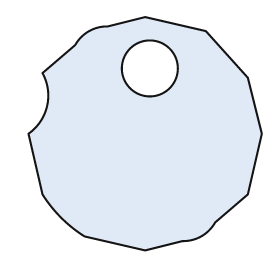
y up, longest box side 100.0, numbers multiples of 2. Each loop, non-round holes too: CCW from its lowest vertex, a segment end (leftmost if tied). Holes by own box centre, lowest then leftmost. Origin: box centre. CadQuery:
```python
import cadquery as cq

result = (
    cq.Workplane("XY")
    .moveTo(0.0, -50.0)
    .lineTo(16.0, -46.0)
    .threePointArc((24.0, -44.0), (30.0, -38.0))
    .lineTo(44.0, -26.0)
    .lineTo(50.0, 0.0)
    .lineTo(44.0, 24.0)
    .lineTo(26.0, 44.0)
    .lineTo(0.0, 50.0)
    .lineTo(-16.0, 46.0)
    .threePointArc((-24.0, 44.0), (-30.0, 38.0))
    .lineTo(-44.0, 26.0)
    .threePointArc((-42.0, 12.0), (-50.0, 0.0))
    .lineTo(-44.0, -26.0)
    .threePointArc((-36.0, -36.0), (-26.0, -44.0))
    .close()
    .moveTo(2.0, 28.0)
    .circle(12.0)
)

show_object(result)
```